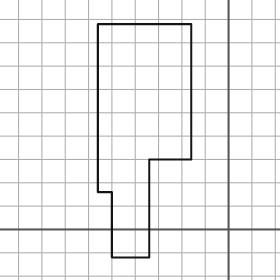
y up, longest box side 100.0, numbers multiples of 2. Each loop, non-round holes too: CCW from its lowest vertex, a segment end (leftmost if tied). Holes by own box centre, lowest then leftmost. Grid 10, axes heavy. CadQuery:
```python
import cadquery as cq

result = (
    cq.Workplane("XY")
    .moveTo(-50.0, -12.0)
    .lineTo(-34.0, -12.0)
    .lineTo(-34.0, 30.0)
    .lineTo(-16.0, 30.0)
    .lineTo(-16.0, 88.0)
    .lineTo(-56.0, 88.0)
    .lineTo(-56.0, 16.0)
    .lineTo(-50.0, 16.0)
    .close()
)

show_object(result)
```